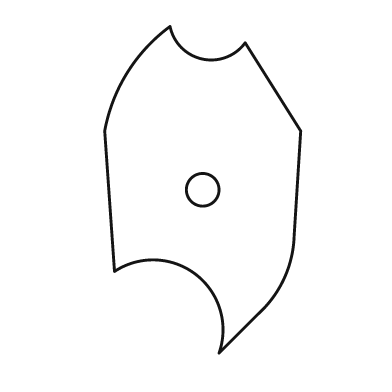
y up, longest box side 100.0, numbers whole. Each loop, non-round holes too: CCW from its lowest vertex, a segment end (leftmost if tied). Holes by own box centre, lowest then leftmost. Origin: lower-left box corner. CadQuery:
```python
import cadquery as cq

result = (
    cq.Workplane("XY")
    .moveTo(35.0, 0.0)
    .lineTo(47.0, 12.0)
    .threePointArc((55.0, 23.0), (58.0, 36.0))
    .lineTo(60.0, 68.0)
    .lineTo(43.0, 95.0)
    .threePointArc((30.0, 90.0), (20.0, 100.0))
    .threePointArc((7.0, 86.0), (0.0, 68.0))
    .lineTo(3.0, 25.0)
    .threePointArc((28.0, 24.0), (35.0, 0.0))
    .close()
    .moveTo(30.0, 50.0)
    .circle(5.0)
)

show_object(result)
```